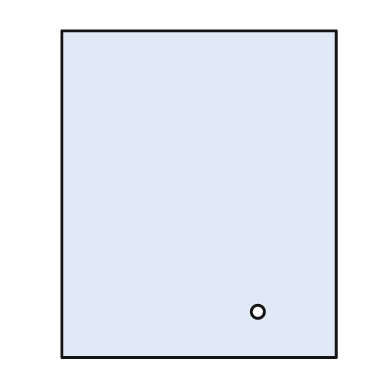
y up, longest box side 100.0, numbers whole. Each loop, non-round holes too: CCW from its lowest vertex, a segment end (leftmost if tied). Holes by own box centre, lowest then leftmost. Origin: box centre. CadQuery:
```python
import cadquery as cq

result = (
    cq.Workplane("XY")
    .moveTo(-42.0, -50.0)
    .lineTo(42.0, -50.0)
    .lineTo(42.0, 50.0)
    .lineTo(-42.0, 50.0)
    .close()
    .moveTo(18.0, -36.0)
    .circle(2.0)
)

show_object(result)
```